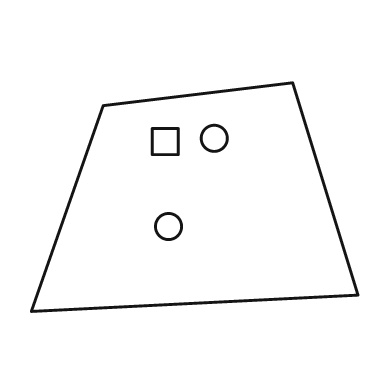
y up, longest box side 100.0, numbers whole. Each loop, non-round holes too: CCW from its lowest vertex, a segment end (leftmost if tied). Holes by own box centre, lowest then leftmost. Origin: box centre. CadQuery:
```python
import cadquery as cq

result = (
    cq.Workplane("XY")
    .moveTo(-50.0, -35.0)
    .lineTo(50.0, -30.0)
    .lineTo(30.0, 35.0)
    .lineTo(-28.0, 28.0)
    .close()
    .moveTo(-8.0, -9.0)
    .circle(4.0)
    .moveTo(-13.0, 13.0)
    .lineTo(-5.0, 13.0)
    .lineTo(-5.0, 21.0)
    .lineTo(-13.0, 21.0)
    .close()
    .moveTo(6.0, 18.0)
    .circle(4.0)
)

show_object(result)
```